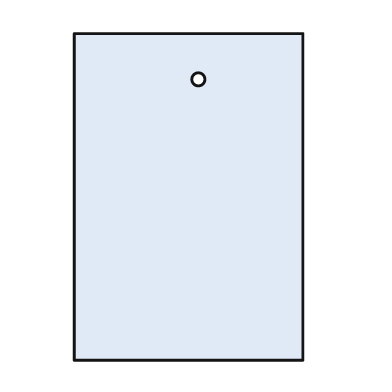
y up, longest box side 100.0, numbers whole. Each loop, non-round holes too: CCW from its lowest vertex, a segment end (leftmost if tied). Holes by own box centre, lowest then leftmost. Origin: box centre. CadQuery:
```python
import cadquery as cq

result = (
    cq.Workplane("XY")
    .moveTo(-35.0, -50.0)
    .lineTo(35.0, -50.0)
    .lineTo(35.0, 50.0)
    .lineTo(-35.0, 50.0)
    .close()
    .moveTo(3.0, 36.0)
    .circle(2.0)
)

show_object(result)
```